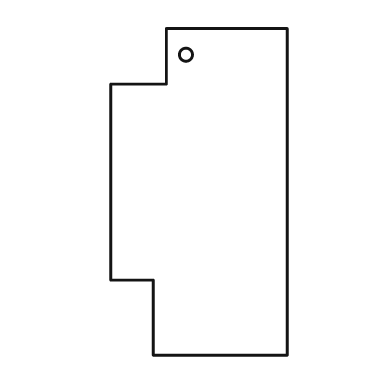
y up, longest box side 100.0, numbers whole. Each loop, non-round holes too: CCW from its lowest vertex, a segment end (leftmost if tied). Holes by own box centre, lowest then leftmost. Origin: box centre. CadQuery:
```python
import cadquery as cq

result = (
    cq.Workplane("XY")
    .moveTo(-14.0, -50.0)
    .lineTo(27.0, -50.0)
    .lineTo(27.0, 50.0)
    .lineTo(-10.0, 50.0)
    .lineTo(-10.0, 33.0)
    .lineTo(-27.0, 33.0)
    .lineTo(-27.0, -27.0)
    .lineTo(-14.0, -27.0)
    .close()
    .moveTo(-4.0, 42.0)
    .circle(2.0)
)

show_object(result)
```